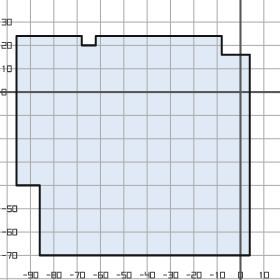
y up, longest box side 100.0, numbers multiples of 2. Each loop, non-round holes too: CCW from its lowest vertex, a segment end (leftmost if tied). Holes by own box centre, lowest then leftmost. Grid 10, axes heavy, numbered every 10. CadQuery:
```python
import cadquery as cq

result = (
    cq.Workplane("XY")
    .moveTo(-86.0, -70.0)
    .lineTo(4.0, -70.0)
    .lineTo(4.0, 16.0)
    .lineTo(-8.0, 16.0)
    .lineTo(-8.0, 24.0)
    .lineTo(-62.0, 24.0)
    .lineTo(-62.0, 20.0)
    .lineTo(-68.0, 20.0)
    .lineTo(-68.0, 24.0)
    .lineTo(-96.0, 24.0)
    .lineTo(-96.0, -40.0)
    .lineTo(-86.0, -40.0)
    .close()
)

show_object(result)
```